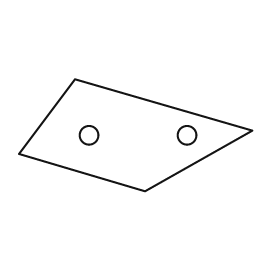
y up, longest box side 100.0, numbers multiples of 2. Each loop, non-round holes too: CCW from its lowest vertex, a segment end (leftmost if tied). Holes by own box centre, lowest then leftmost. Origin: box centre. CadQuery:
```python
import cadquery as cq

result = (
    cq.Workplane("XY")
    .moveTo(4.0, -24.0)
    .lineTo(50.0, 2.0)
    .lineTo(-26.0, 24.0)
    .lineTo(-50.0, -8.0)
    .close()
    .moveTo(-20.0, 0.0)
    .circle(4.0)
    .moveTo(22.0, 0.0)
    .circle(4.0)
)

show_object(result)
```